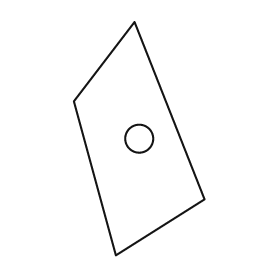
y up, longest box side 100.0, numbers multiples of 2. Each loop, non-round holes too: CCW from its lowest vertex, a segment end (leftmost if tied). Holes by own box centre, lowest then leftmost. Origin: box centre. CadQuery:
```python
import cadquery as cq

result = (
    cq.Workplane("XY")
    .moveTo(-10.0, -50.0)
    .lineTo(28.0, -26.0)
    .lineTo(-2.0, 50.0)
    .lineTo(-28.0, 16.0)
    .close()
    .moveTo(0.0, 0.0)
    .circle(6.0)
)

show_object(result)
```